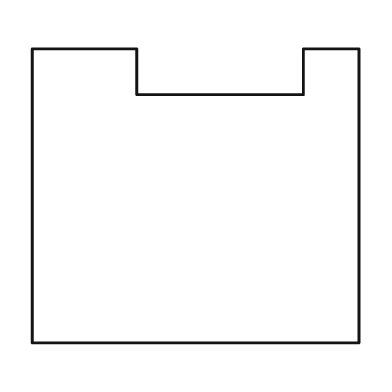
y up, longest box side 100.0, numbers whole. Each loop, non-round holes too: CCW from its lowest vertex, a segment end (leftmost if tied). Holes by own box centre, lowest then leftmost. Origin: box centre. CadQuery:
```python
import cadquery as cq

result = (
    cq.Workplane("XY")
    .moveTo(-50.0, -45.0)
    .lineTo(50.0, -45.0)
    .lineTo(50.0, 45.0)
    .lineTo(33.0, 45.0)
    .lineTo(33.0, 31.0)
    .lineTo(-18.0, 31.0)
    .lineTo(-18.0, 45.0)
    .lineTo(-50.0, 45.0)
    .close()
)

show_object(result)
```